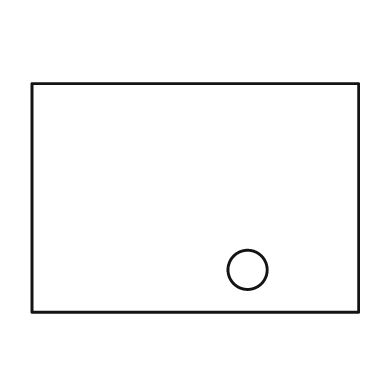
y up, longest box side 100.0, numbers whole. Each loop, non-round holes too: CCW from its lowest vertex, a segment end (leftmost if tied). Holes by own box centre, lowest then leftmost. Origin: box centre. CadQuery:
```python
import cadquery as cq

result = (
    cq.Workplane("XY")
    .moveTo(-50.0, -35.0)
    .lineTo(50.0, -35.0)
    .lineTo(50.0, 35.0)
    .lineTo(-50.0, 35.0)
    .close()
    .moveTo(16.0, -22.0)
    .circle(6.0)
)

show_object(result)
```